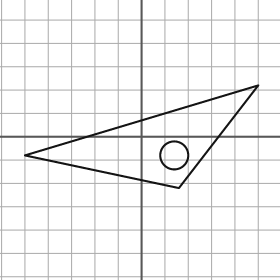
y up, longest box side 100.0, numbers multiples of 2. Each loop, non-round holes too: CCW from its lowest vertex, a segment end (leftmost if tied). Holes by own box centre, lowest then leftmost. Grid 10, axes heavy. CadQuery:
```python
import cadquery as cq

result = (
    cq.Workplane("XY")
    .moveTo(16.0, -22.0)
    .lineTo(50.0, 22.0)
    .lineTo(-50.0, -8.0)
    .close()
    .moveTo(14.0, -8.0)
    .circle(6.0)
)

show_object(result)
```